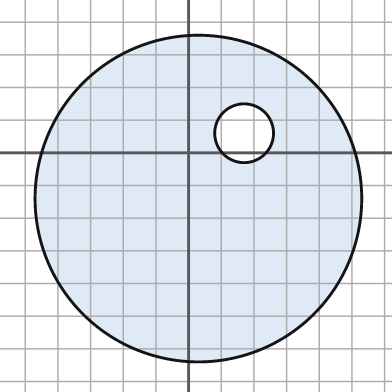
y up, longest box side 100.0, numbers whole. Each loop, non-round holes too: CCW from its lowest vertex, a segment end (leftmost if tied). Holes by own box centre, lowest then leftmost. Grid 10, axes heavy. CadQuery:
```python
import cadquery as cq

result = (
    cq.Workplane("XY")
    .moveTo(3.0, -14.0)
    .circle(50.0)
    .moveTo(17.0, 6.0)
    .circle(9.0)
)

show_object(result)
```